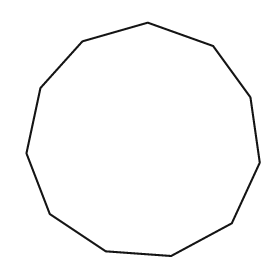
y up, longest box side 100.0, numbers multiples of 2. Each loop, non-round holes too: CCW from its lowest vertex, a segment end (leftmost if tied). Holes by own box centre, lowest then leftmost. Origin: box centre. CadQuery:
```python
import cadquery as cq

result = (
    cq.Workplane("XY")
    .moveTo(12.0, -50.0)
    .lineTo(38.0, -36.0)
    .lineTo(50.0, -10.0)
    .lineTo(46.0, 18.0)
    .lineTo(30.0, 40.0)
    .lineTo(2.0, 50.0)
    .lineTo(-26.0, 42.0)
    .lineTo(-44.0, 22.0)
    .lineTo(-50.0, -6.0)
    .lineTo(-40.0, -32.0)
    .lineTo(-16.0, -48.0)
    .close()
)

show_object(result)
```